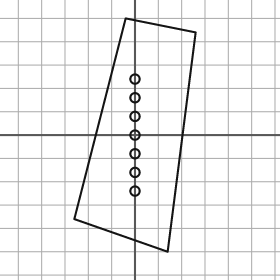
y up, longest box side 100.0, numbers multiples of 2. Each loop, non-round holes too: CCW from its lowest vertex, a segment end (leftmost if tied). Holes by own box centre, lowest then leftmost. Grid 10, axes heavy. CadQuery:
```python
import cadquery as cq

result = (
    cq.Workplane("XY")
    .moveTo(14.0, -50.0)
    .lineTo(26.0, 44.0)
    .lineTo(-4.0, 50.0)
    .lineTo(-26.0, -36.0)
    .close()
    .moveTo(0.0, -24.0)
    .circle(2.0)
    .moveTo(0.0, -16.0)
    .circle(2.0)
    .moveTo(0.0, -8.0)
    .circle(2.0)
    .moveTo(0.0, 0.0)
    .circle(2.0)
    .moveTo(0.0, 8.0)
    .circle(2.0)
    .moveTo(0.0, 16.0)
    .circle(2.0)
    .moveTo(0.0, 24.0)
    .circle(2.0)
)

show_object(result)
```